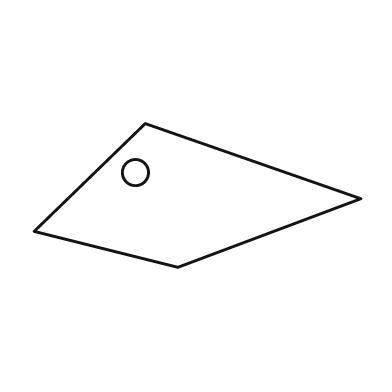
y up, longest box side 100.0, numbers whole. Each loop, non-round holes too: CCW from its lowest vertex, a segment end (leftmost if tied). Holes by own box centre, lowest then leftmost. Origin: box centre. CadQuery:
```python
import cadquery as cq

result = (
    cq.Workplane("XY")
    .moveTo(-6.0, -22.0)
    .lineTo(50.0, -1.0)
    .lineTo(-16.0, 22.0)
    .lineTo(-50.0, -11.0)
    .close()
    .moveTo(-19.0, 7.0)
    .circle(4.0)
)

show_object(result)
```